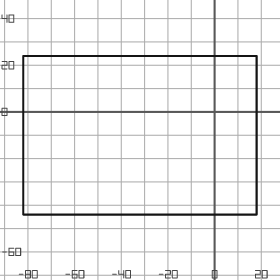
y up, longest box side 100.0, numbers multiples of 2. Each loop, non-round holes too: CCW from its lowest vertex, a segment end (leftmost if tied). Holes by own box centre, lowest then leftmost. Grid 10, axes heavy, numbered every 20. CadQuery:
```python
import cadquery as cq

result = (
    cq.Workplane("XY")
    .moveTo(-82.0, -44.0)
    .lineTo(18.0, -44.0)
    .lineTo(18.0, 24.0)
    .lineTo(-82.0, 24.0)
    .close()
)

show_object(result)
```